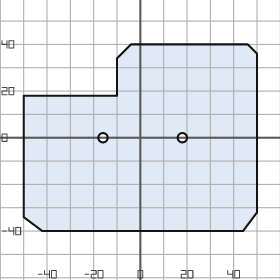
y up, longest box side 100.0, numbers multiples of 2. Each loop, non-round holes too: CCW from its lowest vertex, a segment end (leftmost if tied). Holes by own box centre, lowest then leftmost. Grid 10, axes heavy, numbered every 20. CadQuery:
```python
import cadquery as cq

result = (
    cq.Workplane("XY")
    .moveTo(-42.0, -40.0)
    .lineTo(44.0, -40.0)
    .lineTo(50.0, -32.0)
    .lineTo(50.0, 36.0)
    .lineTo(46.0, 40.0)
    .lineTo(-4.0, 40.0)
    .lineTo(-10.0, 34.0)
    .lineTo(-10.0, 18.0)
    .lineTo(-50.0, 18.0)
    .lineTo(-50.0, -34.0)
    .close()
    .moveTo(-16.0, 0.0)
    .circle(2.0)
    .moveTo(18.0, 0.0)
    .circle(2.0)
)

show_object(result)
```